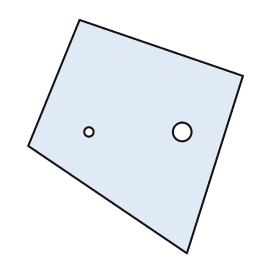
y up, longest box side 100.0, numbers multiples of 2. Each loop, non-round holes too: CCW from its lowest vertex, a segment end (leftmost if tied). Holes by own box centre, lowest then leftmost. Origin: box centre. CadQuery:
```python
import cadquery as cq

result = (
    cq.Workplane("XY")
    .moveTo(22.0, -50.0)
    .lineTo(46.0, 26.0)
    .lineTo(-24.0, 50.0)
    .lineTo(-46.0, -4.0)
    .close()
    .moveTo(-20.0, 2.0)
    .circle(2.0)
    .moveTo(20.0, 2.0)
    .circle(4.0)
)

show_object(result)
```